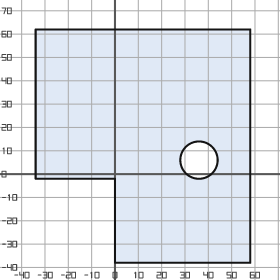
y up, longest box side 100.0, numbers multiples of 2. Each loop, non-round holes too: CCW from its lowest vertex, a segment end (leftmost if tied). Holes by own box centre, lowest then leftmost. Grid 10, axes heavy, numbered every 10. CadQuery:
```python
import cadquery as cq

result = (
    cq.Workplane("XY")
    .moveTo(0.0, -38.0)
    .lineTo(58.0, -38.0)
    .lineTo(58.0, 62.0)
    .lineTo(-34.0, 62.0)
    .lineTo(-34.0, -2.0)
    .lineTo(0.0, -2.0)
    .close()
    .moveTo(36.0, 6.0)
    .circle(8.0)
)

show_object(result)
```